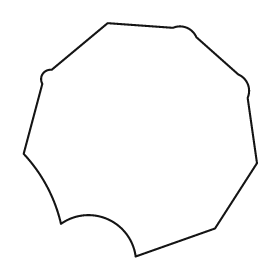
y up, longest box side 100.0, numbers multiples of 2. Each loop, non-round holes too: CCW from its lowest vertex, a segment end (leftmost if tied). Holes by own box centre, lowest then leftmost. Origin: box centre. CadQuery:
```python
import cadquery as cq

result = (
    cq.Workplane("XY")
    .moveTo(-2.0, -50.0)
    .lineTo(32.0, -38.0)
    .lineTo(50.0, -10.0)
    .lineTo(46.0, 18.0)
    .threePointArc((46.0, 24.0), (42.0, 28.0))
    .lineTo(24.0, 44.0)
    .threePointArc((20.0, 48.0), (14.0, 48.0))
    .lineTo(-14.0, 50.0)
    .lineTo(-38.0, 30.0)
    .threePointArc((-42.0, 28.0), (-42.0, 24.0))
    .lineTo(-50.0, -6.0)
    .threePointArc((-40.0, -20.0), (-34.0, -36.0))
    .threePointArc((-14.0, -34.0), (-2.0, -50.0))
    .close()
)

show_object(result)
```